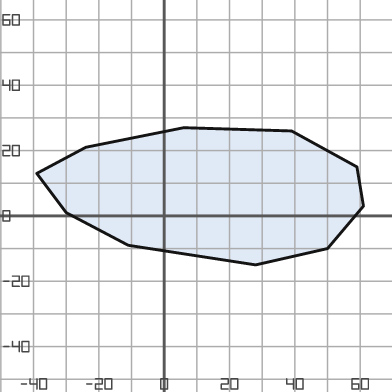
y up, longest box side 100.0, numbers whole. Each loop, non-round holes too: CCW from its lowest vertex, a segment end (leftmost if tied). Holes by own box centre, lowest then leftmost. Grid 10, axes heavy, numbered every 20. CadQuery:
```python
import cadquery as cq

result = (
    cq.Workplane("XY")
    .moveTo(28.0, -15.0)
    .lineTo(50.0, -10.0)
    .lineTo(61.0, 3.0)
    .lineTo(59.0, 15.0)
    .lineTo(39.0, 26.0)
    .lineTo(6.0, 27.0)
    .lineTo(-24.0, 21.0)
    .lineTo(-39.0, 13.0)
    .lineTo(-30.0, 1.0)
    .lineTo(-11.0, -9.0)
    .close()
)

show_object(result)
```